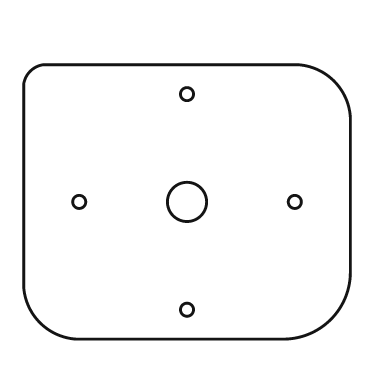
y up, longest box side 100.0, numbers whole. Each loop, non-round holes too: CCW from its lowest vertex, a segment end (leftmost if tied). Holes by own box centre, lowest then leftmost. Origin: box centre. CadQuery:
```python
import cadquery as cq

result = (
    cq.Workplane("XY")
    .moveTo(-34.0, -42.0)
    .lineTo(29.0, -42.0)
    .threePointArc((44.0, -36.0), (50.0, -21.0))
    .lineTo(50.0, 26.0)
    .threePointArc((45.0, 37.0), (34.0, 42.0))
    .lineTo(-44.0, 42.0)
    .threePointArc((-48.0, 40.0), (-50.0, 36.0))
    .lineTo(-50.0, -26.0)
    .threePointArc((-45.0, -37.0), (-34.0, -42.0))
    .close()
    .moveTo(0.0, -33.0)
    .circle(2.0)
    .moveTo(-33.0, 0.0)
    .circle(2.0)
    .moveTo(0.0, 0.0)
    .circle(6.0)
    .moveTo(33.0, 0.0)
    .circle(2.0)
    .moveTo(0.0, 33.0)
    .circle(2.0)
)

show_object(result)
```